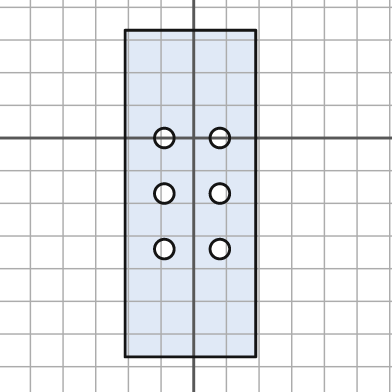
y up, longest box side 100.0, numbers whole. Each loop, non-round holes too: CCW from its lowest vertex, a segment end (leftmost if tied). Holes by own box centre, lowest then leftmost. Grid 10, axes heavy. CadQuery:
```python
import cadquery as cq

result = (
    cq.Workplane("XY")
    .moveTo(-21.0, -67.0)
    .lineTo(19.0, -67.0)
    .lineTo(19.0, 33.0)
    .lineTo(-21.0, 33.0)
    .close()
    .moveTo(-9.0, -34.0)
    .circle(3.0)
    .moveTo(8.0, -34.0)
    .circle(3.0)
    .moveTo(-9.0, -17.0)
    .circle(3.0)
    .moveTo(8.0, -17.0)
    .circle(3.0)
    .moveTo(-9.0, 0.0)
    .circle(3.0)
    .moveTo(8.0, 0.0)
    .circle(3.0)
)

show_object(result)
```